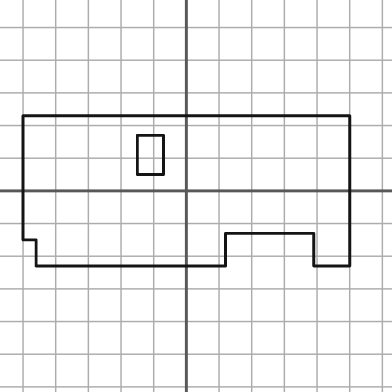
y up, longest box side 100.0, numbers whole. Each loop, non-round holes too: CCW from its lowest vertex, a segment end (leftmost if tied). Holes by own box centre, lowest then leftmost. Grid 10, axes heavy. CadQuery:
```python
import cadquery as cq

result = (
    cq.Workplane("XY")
    .moveTo(-46.0, -23.0)
    .lineTo(12.0, -23.0)
    .lineTo(12.0, -13.0)
    .lineTo(39.0, -13.0)
    .lineTo(39.0, -23.0)
    .lineTo(50.0, -23.0)
    .lineTo(50.0, 23.0)
    .lineTo(-50.0, 23.0)
    .lineTo(-50.0, -15.0)
    .lineTo(-46.0, -15.0)
    .close()
    .moveTo(-15.0, 5.0)
    .lineTo(-7.0, 5.0)
    .lineTo(-7.0, 17.0)
    .lineTo(-15.0, 17.0)
    .close()
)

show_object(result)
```